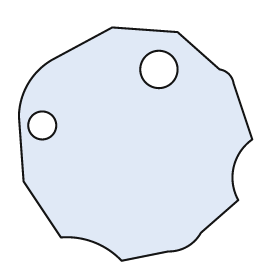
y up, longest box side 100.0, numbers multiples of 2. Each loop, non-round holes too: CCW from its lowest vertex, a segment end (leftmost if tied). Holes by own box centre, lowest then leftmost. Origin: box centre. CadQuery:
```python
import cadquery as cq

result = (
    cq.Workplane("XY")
    .moveTo(-6.0, -50.0)
    .lineTo(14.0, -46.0)
    .threePointArc((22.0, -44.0), (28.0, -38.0))
    .lineTo(44.0, -24.0)
    .threePointArc((42.0, -10.0), (50.0, 2.0))
    .lineTo(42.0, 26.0)
    .threePointArc((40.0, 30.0), (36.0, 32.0))
    .lineTo(18.0, 48.0)
    .lineTo(-10.0, 50.0)
    .lineTo(-36.0, 36.0)
    .threePointArc((-46.0, 26.0), (-50.0, 12.0))
    .lineTo(-48.0, -16.0)
    .lineTo(-32.0, -40.0)
    .threePointArc((-18.0, -42.0), (-6.0, -50.0))
    .close()
    .moveTo(-40.0, 8.0)
    .circle(6.0)
    .moveTo(10.0, 32.0)
    .circle(8.0)
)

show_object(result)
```